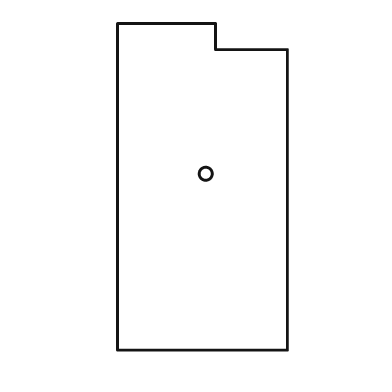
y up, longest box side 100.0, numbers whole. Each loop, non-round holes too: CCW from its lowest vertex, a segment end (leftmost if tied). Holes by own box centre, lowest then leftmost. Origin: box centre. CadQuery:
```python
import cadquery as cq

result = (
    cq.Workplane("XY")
    .moveTo(-26.0, -50.0)
    .lineTo(26.0, -50.0)
    .lineTo(26.0, 42.0)
    .lineTo(4.0, 42.0)
    .lineTo(4.0, 50.0)
    .lineTo(-26.0, 50.0)
    .close()
    .moveTo(1.0, 4.0)
    .circle(2.0)
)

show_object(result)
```